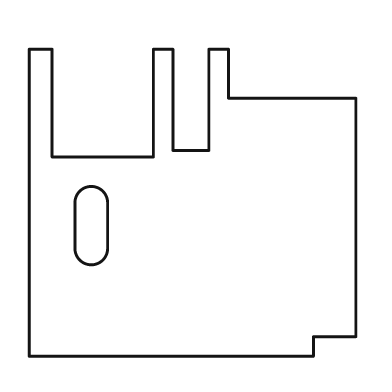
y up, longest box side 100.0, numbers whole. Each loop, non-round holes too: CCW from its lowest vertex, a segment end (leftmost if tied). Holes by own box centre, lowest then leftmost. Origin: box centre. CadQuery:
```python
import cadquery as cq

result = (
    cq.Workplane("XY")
    .moveTo(-50.0, -47.0)
    .lineTo(37.0, -47.0)
    .lineTo(37.0, -41.0)
    .lineTo(50.0, -41.0)
    .lineTo(50.0, 32.0)
    .lineTo(11.0, 32.0)
    .lineTo(11.0, 47.0)
    .lineTo(5.0, 47.0)
    .lineTo(5.0, 16.0)
    .lineTo(-6.0, 16.0)
    .lineTo(-6.0, 47.0)
    .lineTo(-12.0, 47.0)
    .lineTo(-12.0, 14.0)
    .lineTo(-43.0, 14.0)
    .lineTo(-43.0, 47.0)
    .lineTo(-50.0, 47.0)
    .close()
    .moveTo(-36.0, -14.0)
    .threePointArc((-31.0, -19.0), (-26.0, -14.0))
    .lineTo(-26.0, 0.0)
    .threePointArc((-31.0, 5.0), (-36.0, 0.0))
    .close()
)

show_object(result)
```